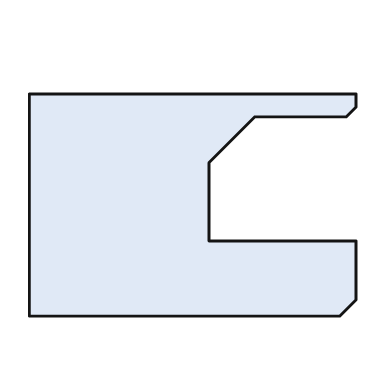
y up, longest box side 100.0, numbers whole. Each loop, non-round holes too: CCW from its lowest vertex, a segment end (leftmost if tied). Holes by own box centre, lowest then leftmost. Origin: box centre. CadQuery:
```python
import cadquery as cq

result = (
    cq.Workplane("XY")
    .moveTo(-50.0, -34.0)
    .lineTo(45.0, -34.0)
    .lineTo(50.0, -29.0)
    .lineTo(50.0, -11.0)
    .lineTo(5.0, -11.0)
    .lineTo(5.0, 13.0)
    .lineTo(19.0, 27.0)
    .lineTo(47.0, 27.0)
    .lineTo(50.0, 30.0)
    .lineTo(50.0, 34.0)
    .lineTo(-50.0, 34.0)
    .close()
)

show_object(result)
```